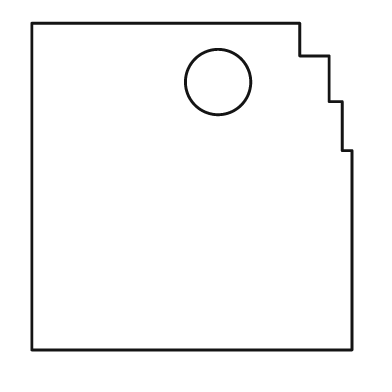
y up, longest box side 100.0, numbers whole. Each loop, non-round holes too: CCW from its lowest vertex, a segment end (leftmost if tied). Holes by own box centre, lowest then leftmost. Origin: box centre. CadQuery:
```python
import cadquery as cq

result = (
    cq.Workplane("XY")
    .moveTo(-49.0, -50.0)
    .lineTo(49.0, -50.0)
    .lineTo(49.0, 11.0)
    .lineTo(46.0, 11.0)
    .lineTo(46.0, 26.0)
    .lineTo(42.0, 26.0)
    .lineTo(42.0, 40.0)
    .lineTo(33.0, 40.0)
    .lineTo(33.0, 50.0)
    .lineTo(-49.0, 50.0)
    .close()
    .moveTo(8.0, 32.0)
    .circle(10.0)
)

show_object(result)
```